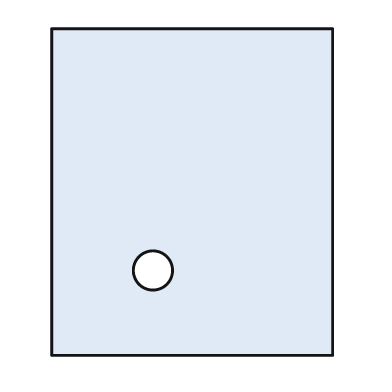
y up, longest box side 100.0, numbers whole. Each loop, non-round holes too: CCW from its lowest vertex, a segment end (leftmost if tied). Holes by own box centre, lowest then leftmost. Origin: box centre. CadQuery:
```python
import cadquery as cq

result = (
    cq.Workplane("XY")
    .moveTo(-43.0, -50.0)
    .lineTo(43.0, -50.0)
    .lineTo(43.0, 50.0)
    .lineTo(-43.0, 50.0)
    .close()
    .moveTo(-12.0, -24.0)
    .circle(6.0)
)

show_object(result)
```